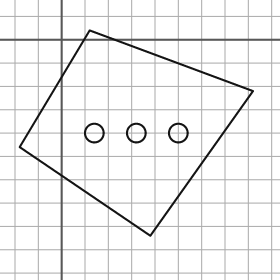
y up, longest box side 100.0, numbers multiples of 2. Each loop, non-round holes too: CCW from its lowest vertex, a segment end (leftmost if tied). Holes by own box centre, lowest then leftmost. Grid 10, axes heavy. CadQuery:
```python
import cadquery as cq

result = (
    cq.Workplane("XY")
    .moveTo(38.0, -84.0)
    .lineTo(82.0, -22.0)
    .lineTo(12.0, 4.0)
    .lineTo(-18.0, -46.0)
    .close()
    .moveTo(14.0, -40.0)
    .circle(4.0)
    .moveTo(32.0, -40.0)
    .circle(4.0)
    .moveTo(50.0, -40.0)
    .circle(4.0)
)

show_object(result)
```